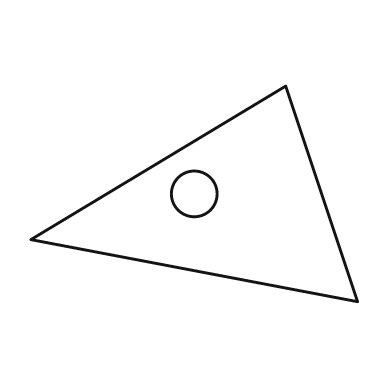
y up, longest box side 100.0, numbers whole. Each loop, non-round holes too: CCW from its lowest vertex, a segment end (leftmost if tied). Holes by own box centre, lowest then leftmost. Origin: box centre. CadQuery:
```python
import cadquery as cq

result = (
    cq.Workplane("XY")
    .moveTo(50.0, -33.0)
    .lineTo(28.0, 33.0)
    .lineTo(-50.0, -14.0)
    .close()
    .moveTo(0.0, 0.0)
    .circle(7.0)
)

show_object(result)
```